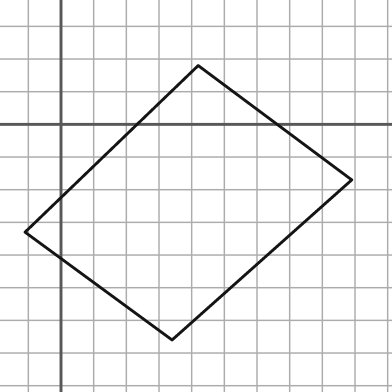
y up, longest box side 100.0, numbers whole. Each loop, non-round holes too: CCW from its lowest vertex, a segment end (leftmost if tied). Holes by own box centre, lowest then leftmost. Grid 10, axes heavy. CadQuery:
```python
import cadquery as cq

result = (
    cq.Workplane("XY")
    .moveTo(34.0, -66.0)
    .lineTo(89.0, -17.0)
    .lineTo(42.0, 18.0)
    .lineTo(-11.0, -33.0)
    .close()
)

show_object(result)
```